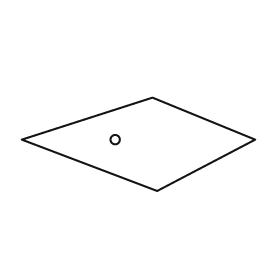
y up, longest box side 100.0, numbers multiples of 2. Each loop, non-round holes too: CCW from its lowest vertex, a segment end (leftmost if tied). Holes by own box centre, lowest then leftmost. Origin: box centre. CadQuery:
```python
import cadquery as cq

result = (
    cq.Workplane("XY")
    .moveTo(8.0, -20.0)
    .lineTo(50.0, 2.0)
    .lineTo(6.0, 20.0)
    .lineTo(-50.0, 2.0)
    .close()
    .moveTo(-10.0, 2.0)
    .circle(2.0)
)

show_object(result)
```